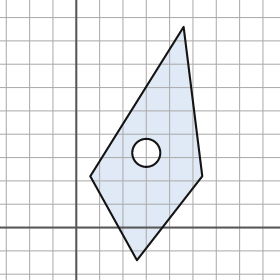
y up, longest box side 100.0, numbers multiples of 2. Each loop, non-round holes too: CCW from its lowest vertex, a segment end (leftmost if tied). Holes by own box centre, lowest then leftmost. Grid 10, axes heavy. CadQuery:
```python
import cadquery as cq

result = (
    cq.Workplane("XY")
    .moveTo(26.0, -14.0)
    .lineTo(54.0, 22.0)
    .lineTo(46.0, 86.0)
    .lineTo(6.0, 22.0)
    .close()
    .moveTo(30.0, 32.0)
    .circle(6.0)
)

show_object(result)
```